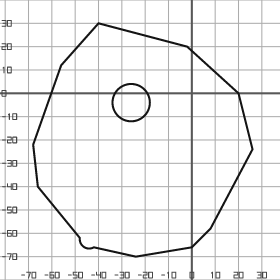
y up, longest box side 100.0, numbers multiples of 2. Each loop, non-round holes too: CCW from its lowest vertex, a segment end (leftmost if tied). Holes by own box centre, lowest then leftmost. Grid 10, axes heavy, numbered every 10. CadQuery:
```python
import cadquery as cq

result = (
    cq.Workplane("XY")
    .moveTo(-24.0, -70.0)
    .lineTo(0.0, -66.0)
    .lineTo(8.0, -58.0)
    .lineTo(26.0, -24.0)
    .lineTo(20.0, 0.0)
    .lineTo(-2.0, 20.0)
    .lineTo(-40.0, 30.0)
    .lineTo(-56.0, 12.0)
    .lineTo(-68.0, -22.0)
    .lineTo(-66.0, -40.0)
    .lineTo(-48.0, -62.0)
    .threePointArc((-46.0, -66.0), (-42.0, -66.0))
    .close()
    .moveTo(-26.0, -4.0)
    .circle(8.0)
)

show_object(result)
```